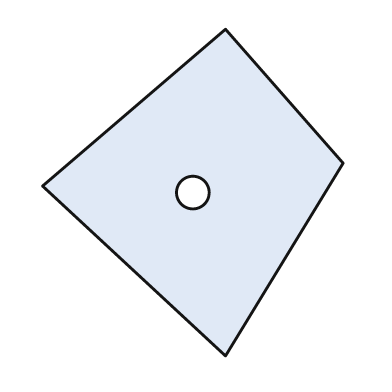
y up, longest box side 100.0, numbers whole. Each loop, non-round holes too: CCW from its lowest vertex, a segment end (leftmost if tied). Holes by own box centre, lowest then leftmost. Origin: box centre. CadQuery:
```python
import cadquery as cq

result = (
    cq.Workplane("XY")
    .moveTo(10.0, -50.0)
    .lineTo(46.0, 9.0)
    .lineTo(10.0, 50.0)
    .lineTo(-46.0, 2.0)
    .close()
    .moveTo(0.0, 0.0)
    .circle(5.0)
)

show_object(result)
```